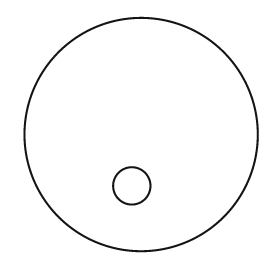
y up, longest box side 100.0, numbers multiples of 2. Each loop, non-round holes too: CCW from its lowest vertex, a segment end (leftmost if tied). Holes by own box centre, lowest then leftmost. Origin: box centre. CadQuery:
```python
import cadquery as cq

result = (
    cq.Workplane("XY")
    .moveTo(0.0, 0.0)
    .circle(50.0)
    .moveTo(-4.0, -22.0)
    .circle(8.0)
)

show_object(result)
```